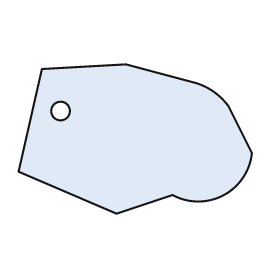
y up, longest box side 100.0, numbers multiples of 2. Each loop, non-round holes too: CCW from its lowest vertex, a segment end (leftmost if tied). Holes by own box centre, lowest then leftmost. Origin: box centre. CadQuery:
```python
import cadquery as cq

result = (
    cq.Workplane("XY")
    .moveTo(-8.0, -32.0)
    .lineTo(16.0, -24.0)
    .threePointArc((38.0, -24.0), (50.0, -6.0))
    .lineTo(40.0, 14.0)
    .threePointArc((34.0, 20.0), (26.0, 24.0))
    .lineTo(-4.0, 32.0)
    .lineTo(-40.0, 30.0)
    .lineTo(-50.0, -14.0)
    .close()
    .moveTo(-32.0, 12.0)
    .circle(4.0)
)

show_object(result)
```